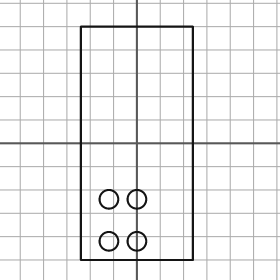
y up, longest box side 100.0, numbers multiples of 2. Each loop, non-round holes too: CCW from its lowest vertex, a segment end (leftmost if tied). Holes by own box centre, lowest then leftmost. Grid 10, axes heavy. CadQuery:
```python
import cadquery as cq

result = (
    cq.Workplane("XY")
    .moveTo(-24.0, -50.0)
    .lineTo(24.0, -50.0)
    .lineTo(24.0, 50.0)
    .lineTo(-24.0, 50.0)
    .close()
    .moveTo(-12.0, -42.0)
    .circle(4.0)
    .moveTo(0.0, -42.0)
    .circle(4.0)
    .moveTo(-12.0, -24.0)
    .circle(4.0)
    .moveTo(0.0, -24.0)
    .circle(4.0)
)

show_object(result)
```